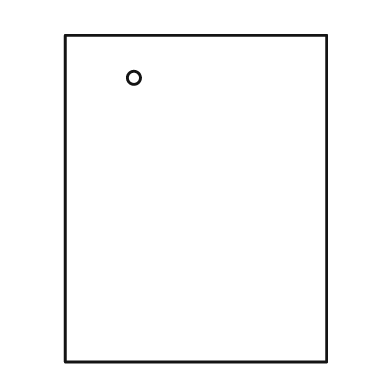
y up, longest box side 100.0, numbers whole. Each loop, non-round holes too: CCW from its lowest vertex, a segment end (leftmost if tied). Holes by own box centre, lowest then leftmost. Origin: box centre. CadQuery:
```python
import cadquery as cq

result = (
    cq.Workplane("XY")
    .moveTo(-40.0, -50.0)
    .lineTo(40.0, -50.0)
    .lineTo(40.0, 50.0)
    .lineTo(-40.0, 50.0)
    .close()
    .moveTo(-19.0, 37.0)
    .circle(2.0)
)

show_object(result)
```